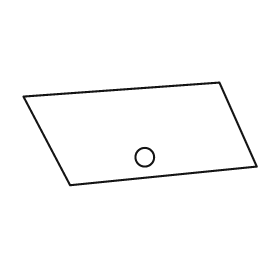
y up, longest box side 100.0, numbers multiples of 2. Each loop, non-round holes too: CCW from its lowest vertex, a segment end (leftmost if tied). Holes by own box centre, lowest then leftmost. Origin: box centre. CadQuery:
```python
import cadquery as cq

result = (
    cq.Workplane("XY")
    .moveTo(-30.0, -22.0)
    .lineTo(50.0, -14.0)
    .lineTo(34.0, 22.0)
    .lineTo(-50.0, 16.0)
    .close()
    .moveTo(2.0, -10.0)
    .circle(4.0)
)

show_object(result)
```